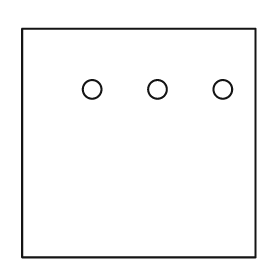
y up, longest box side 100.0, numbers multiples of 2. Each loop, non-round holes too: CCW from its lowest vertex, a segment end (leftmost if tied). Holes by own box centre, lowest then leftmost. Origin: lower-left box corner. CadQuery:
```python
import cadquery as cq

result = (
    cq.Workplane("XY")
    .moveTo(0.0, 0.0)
    .lineTo(100.0, 0.0)
    .lineTo(100.0, 98.0)
    .lineTo(0.0, 98.0)
    .close()
    .moveTo(30.0, 72.0)
    .circle(4.0)
    .moveTo(58.0, 72.0)
    .circle(4.0)
    .moveTo(86.0, 72.0)
    .circle(4.0)
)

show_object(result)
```